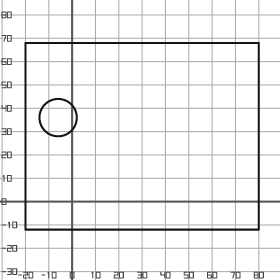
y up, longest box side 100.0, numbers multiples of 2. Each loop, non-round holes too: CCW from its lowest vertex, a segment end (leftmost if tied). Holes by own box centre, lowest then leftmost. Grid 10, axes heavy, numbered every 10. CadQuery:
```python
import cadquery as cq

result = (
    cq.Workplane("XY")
    .moveTo(-20.0, -12.0)
    .lineTo(80.0, -12.0)
    .lineTo(80.0, 68.0)
    .lineTo(-20.0, 68.0)
    .close()
    .moveTo(-6.0, 36.0)
    .circle(8.0)
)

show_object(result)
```